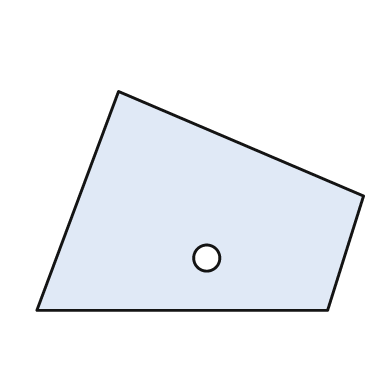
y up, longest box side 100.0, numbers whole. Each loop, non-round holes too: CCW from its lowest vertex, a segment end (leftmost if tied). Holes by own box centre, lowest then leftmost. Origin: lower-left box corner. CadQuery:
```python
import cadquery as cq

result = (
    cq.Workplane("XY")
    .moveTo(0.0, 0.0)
    .lineTo(89.0, 0.0)
    .lineTo(100.0, 35.0)
    .lineTo(25.0, 67.0)
    .close()
    .moveTo(52.0, 16.0)
    .circle(4.0)
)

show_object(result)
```